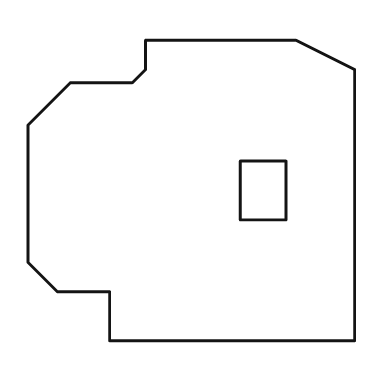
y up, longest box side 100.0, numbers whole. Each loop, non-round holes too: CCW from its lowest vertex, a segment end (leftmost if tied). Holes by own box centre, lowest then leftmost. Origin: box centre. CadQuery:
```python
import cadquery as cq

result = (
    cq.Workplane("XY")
    .moveTo(-25.0, -46.0)
    .lineTo(50.0, -46.0)
    .lineTo(50.0, 37.0)
    .lineTo(32.0, 46.0)
    .lineTo(-14.0, 46.0)
    .lineTo(-14.0, 37.0)
    .lineTo(-18.0, 33.0)
    .lineTo(-37.0, 33.0)
    .lineTo(-50.0, 20.0)
    .lineTo(-50.0, -22.0)
    .lineTo(-41.0, -31.0)
    .lineTo(-25.0, -31.0)
    .close()
    .moveTo(15.0, -9.0)
    .lineTo(29.0, -9.0)
    .lineTo(29.0, 9.0)
    .lineTo(15.0, 9.0)
    .close()
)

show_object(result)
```